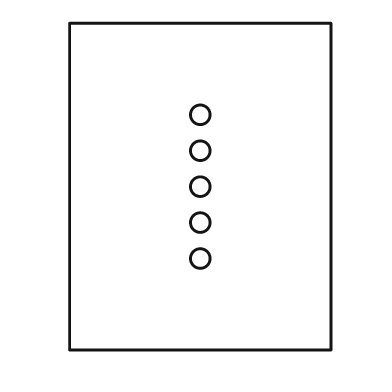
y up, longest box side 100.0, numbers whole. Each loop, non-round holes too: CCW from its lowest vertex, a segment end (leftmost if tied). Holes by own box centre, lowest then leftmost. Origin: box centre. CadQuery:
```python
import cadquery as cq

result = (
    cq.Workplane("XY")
    .moveTo(-40.0, -50.0)
    .lineTo(40.0, -50.0)
    .lineTo(40.0, 50.0)
    .lineTo(-40.0, 50.0)
    .close()
    .moveTo(0.0, -22.0)
    .circle(3.0)
    .moveTo(0.0, -11.0)
    .circle(3.0)
    .moveTo(0.0, 0.0)
    .circle(3.0)
    .moveTo(0.0, 11.0)
    .circle(3.0)
    .moveTo(0.0, 22.0)
    .circle(3.0)
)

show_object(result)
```